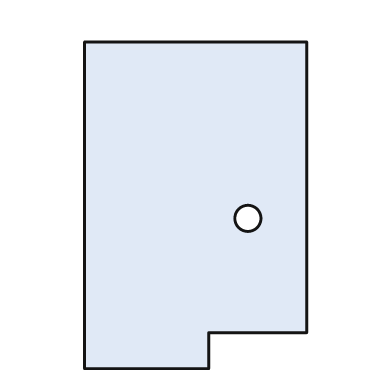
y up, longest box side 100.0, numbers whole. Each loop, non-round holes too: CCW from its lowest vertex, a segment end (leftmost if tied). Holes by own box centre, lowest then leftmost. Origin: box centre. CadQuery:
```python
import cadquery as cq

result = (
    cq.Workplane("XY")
    .moveTo(-34.0, -50.0)
    .lineTo(4.0, -50.0)
    .lineTo(4.0, -39.0)
    .lineTo(34.0, -39.0)
    .lineTo(34.0, 50.0)
    .lineTo(-34.0, 50.0)
    .close()
    .moveTo(16.0, -4.0)
    .circle(4.0)
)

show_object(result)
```